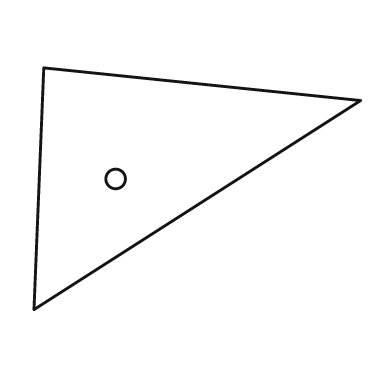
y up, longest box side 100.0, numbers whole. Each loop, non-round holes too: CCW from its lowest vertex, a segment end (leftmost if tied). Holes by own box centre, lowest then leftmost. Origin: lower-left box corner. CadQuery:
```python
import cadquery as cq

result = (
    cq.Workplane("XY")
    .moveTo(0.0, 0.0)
    .lineTo(100.0, 64.0)
    .lineTo(3.0, 74.0)
    .close()
    .moveTo(25.0, 40.0)
    .circle(3.0)
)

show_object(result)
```